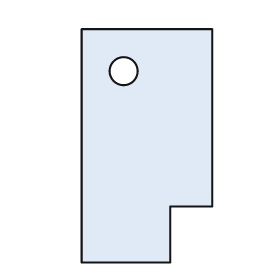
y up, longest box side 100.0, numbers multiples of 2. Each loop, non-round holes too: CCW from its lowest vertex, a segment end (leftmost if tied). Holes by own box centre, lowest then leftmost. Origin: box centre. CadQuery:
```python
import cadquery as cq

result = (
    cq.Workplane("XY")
    .moveTo(-28.0, -50.0)
    .lineTo(10.0, -50.0)
    .lineTo(10.0, -26.0)
    .lineTo(28.0, -26.0)
    .lineTo(28.0, 50.0)
    .lineTo(-28.0, 50.0)
    .close()
    .moveTo(-10.0, 32.0)
    .circle(6.0)
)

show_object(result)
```